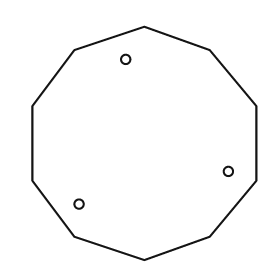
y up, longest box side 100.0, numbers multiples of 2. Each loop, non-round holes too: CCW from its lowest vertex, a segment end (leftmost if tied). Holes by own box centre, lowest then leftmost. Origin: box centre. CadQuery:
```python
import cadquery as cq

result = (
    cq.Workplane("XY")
    .moveTo(0.0, -50.0)
    .lineTo(28.0, -40.0)
    .lineTo(48.0, -16.0)
    .lineTo(48.0, 16.0)
    .lineTo(28.0, 40.0)
    .lineTo(0.0, 50.0)
    .lineTo(-30.0, 40.0)
    .lineTo(-48.0, 16.0)
    .lineTo(-48.0, -16.0)
    .lineTo(-30.0, -40.0)
    .close()
    .moveTo(-28.0, -26.0)
    .circle(2.0)
    .moveTo(36.0, -12.0)
    .circle(2.0)
    .moveTo(-8.0, 36.0)
    .circle(2.0)
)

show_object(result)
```